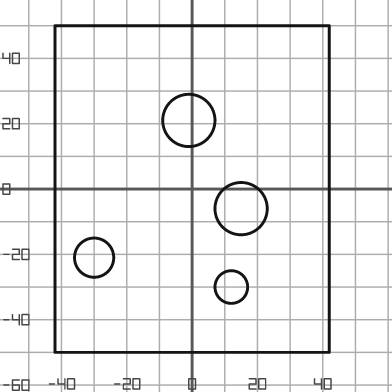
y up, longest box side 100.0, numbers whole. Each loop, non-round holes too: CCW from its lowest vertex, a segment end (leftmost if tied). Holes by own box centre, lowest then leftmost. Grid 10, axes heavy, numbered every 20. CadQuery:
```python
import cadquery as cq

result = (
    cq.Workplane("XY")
    .moveTo(-42.0, -50.0)
    .lineTo(42.0, -50.0)
    .lineTo(42.0, 50.0)
    .lineTo(-42.0, 50.0)
    .close()
    .moveTo(12.0, -30.0)
    .circle(5.0)
    .moveTo(-30.0, -21.0)
    .circle(6.0)
    .moveTo(15.0, -6.0)
    .circle(8.0)
    .moveTo(-1.0, 21.0)
    .circle(8.0)
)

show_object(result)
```